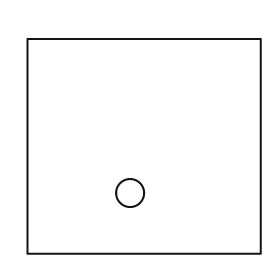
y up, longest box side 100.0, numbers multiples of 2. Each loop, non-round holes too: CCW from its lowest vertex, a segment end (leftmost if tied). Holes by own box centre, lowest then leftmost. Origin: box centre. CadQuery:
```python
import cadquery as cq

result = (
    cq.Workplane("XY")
    .moveTo(-50.0, -46.0)
    .lineTo(50.0, -46.0)
    .lineTo(50.0, 46.0)
    .lineTo(-50.0, 46.0)
    .close()
    .moveTo(-6.0, -20.0)
    .circle(6.0)
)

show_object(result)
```